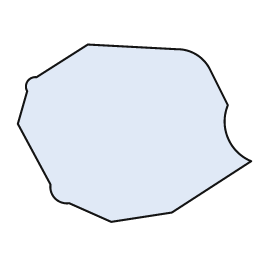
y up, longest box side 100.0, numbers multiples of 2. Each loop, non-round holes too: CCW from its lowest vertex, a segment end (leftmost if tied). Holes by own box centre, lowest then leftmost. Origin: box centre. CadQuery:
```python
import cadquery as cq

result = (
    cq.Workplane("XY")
    .moveTo(-10.0, -38.0)
    .lineTo(16.0, -34.0)
    .lineTo(50.0, -12.0)
    .threePointArc((40.0, -2.0), (40.0, 12.0))
    .lineTo(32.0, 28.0)
    .threePointArc((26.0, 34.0), (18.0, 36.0))
    .lineTo(-20.0, 38.0)
    .lineTo(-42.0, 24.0)
    .threePointArc((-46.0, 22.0), (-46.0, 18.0))
    .lineTo(-50.0, 4.0)
    .lineTo(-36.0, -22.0)
    .threePointArc((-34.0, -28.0), (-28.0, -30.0))
    .close()
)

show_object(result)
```